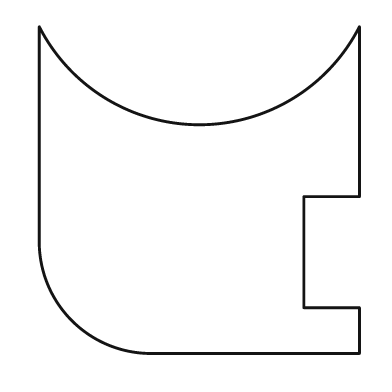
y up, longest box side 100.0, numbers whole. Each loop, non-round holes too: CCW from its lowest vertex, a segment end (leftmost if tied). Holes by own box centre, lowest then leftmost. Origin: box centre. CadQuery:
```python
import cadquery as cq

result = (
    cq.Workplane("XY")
    .moveTo(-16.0, -50.0)
    .lineTo(49.0, -50.0)
    .lineTo(49.0, -36.0)
    .lineTo(32.0, -36.0)
    .lineTo(32.0, -2.0)
    .lineTo(49.0, -2.0)
    .lineTo(49.0, 50.0)
    .threePointArc((0.0, 20.0), (-49.0, 50.0))
    .lineTo(-49.0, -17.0)
    .threePointArc((-39.0, -40.0), (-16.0, -50.0))
    .close()
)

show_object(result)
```